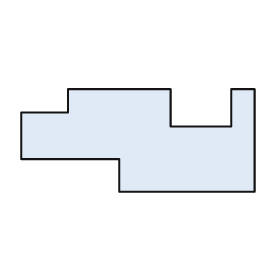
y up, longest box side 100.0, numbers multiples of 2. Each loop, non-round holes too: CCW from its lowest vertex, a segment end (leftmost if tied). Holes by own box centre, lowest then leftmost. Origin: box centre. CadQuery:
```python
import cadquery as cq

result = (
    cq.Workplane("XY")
    .moveTo(-8.0, -22.0)
    .lineTo(50.0, -22.0)
    .lineTo(50.0, 22.0)
    .lineTo(40.0, 22.0)
    .lineTo(40.0, 6.0)
    .lineTo(14.0, 6.0)
    .lineTo(14.0, 22.0)
    .lineTo(-30.0, 22.0)
    .lineTo(-30.0, 12.0)
    .lineTo(-50.0, 12.0)
    .lineTo(-50.0, -8.0)
    .lineTo(-8.0, -8.0)
    .close()
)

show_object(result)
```